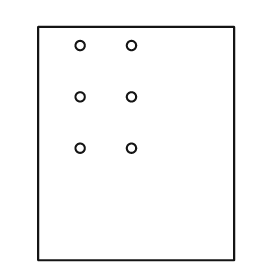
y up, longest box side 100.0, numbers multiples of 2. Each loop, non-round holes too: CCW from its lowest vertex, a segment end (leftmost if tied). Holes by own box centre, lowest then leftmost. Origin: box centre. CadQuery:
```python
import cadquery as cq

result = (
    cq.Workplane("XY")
    .moveTo(-42.0, -50.0)
    .lineTo(42.0, -50.0)
    .lineTo(42.0, 50.0)
    .lineTo(-42.0, 50.0)
    .close()
    .moveTo(-24.0, -2.0)
    .circle(2.0)
    .moveTo(-2.0, -2.0)
    .circle(2.0)
    .moveTo(-24.0, 20.0)
    .circle(2.0)
    .moveTo(-2.0, 20.0)
    .circle(2.0)
    .moveTo(-24.0, 42.0)
    .circle(2.0)
    .moveTo(-2.0, 42.0)
    .circle(2.0)
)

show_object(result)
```